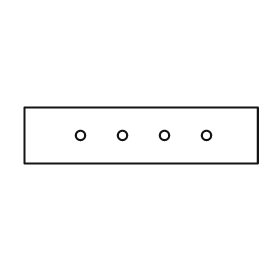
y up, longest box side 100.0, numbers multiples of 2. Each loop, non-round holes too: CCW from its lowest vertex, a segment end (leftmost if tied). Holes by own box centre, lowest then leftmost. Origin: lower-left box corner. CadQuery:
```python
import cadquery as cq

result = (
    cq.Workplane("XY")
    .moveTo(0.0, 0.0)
    .lineTo(100.0, 0.0)
    .lineTo(100.0, 24.0)
    .lineTo(0.0, 24.0)
    .close()
    .moveTo(24.0, 12.0)
    .circle(2.0)
    .moveTo(42.0, 12.0)
    .circle(2.0)
    .moveTo(60.0, 12.0)
    .circle(2.0)
    .moveTo(78.0, 12.0)
    .circle(2.0)
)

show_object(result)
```